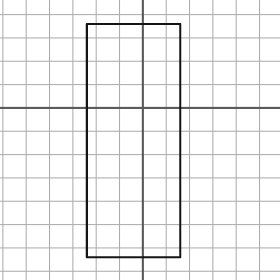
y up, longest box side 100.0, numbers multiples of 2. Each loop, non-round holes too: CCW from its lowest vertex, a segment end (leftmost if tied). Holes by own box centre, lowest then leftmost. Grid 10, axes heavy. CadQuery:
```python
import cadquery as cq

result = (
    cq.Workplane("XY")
    .moveTo(-24.0, -64.0)
    .lineTo(16.0, -64.0)
    .lineTo(16.0, 36.0)
    .lineTo(-24.0, 36.0)
    .close()
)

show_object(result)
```